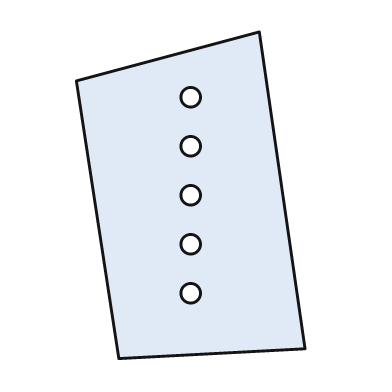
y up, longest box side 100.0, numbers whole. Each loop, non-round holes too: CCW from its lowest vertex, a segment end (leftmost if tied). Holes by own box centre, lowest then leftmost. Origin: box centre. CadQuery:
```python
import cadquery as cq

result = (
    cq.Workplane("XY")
    .moveTo(-22.0, -50.0)
    .lineTo(35.0, -47.0)
    .lineTo(21.0, 50.0)
    .lineTo(-35.0, 35.0)
    .close()
    .moveTo(0.0, -30.0)
    .circle(3.0)
    .moveTo(0.0, -15.0)
    .circle(3.0)
    .moveTo(0.0, 0.0)
    .circle(3.0)
    .moveTo(0.0, 15.0)
    .circle(3.0)
    .moveTo(0.0, 30.0)
    .circle(3.0)
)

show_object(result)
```